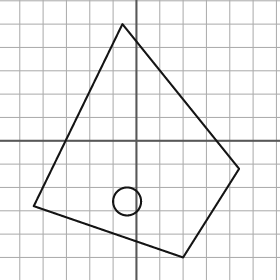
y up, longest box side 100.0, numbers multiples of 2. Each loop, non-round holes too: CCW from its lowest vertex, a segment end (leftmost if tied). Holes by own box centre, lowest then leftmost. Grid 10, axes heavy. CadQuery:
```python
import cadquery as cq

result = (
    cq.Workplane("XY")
    .moveTo(20.0, -50.0)
    .lineTo(44.0, -12.0)
    .lineTo(-6.0, 50.0)
    .lineTo(-44.0, -28.0)
    .close()
    .moveTo(-4.0, -26.0)
    .circle(6.0)
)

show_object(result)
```